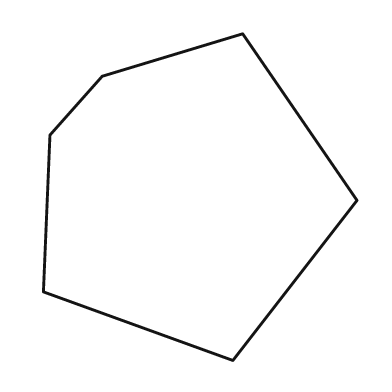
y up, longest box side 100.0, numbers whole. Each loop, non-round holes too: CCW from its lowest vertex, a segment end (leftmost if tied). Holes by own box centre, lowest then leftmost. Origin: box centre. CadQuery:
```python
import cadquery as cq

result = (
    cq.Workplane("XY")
    .moveTo(10.0, -50.0)
    .lineTo(48.0, -1.0)
    .lineTo(13.0, 50.0)
    .lineTo(-30.0, 37.0)
    .lineTo(-46.0, 19.0)
    .lineTo(-48.0, -29.0)
    .close()
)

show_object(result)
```